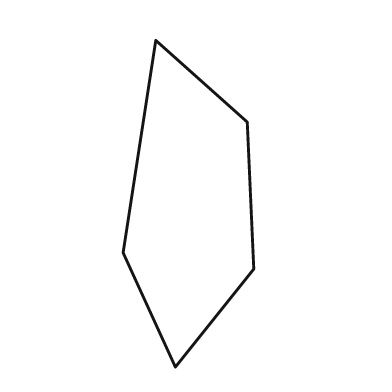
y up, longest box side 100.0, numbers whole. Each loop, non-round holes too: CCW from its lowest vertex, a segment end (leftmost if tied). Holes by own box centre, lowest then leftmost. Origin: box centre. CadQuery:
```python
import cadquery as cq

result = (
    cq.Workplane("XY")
    .moveTo(-4.0, -50.0)
    .lineTo(20.0, -20.0)
    .lineTo(18.0, 25.0)
    .lineTo(-10.0, 50.0)
    .lineTo(-20.0, -15.0)
    .close()
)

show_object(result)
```